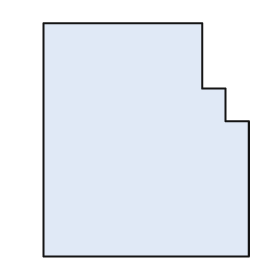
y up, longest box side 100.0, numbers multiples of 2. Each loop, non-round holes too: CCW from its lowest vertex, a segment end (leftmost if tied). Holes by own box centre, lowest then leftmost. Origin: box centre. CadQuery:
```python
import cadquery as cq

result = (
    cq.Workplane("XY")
    .moveTo(-44.0, -50.0)
    .lineTo(44.0, -50.0)
    .lineTo(44.0, 8.0)
    .lineTo(34.0, 8.0)
    .lineTo(34.0, 22.0)
    .lineTo(24.0, 22.0)
    .lineTo(24.0, 50.0)
    .lineTo(-44.0, 50.0)
    .close()
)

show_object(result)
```